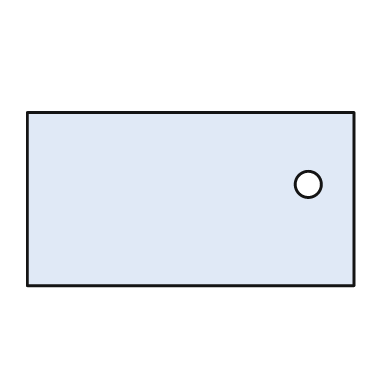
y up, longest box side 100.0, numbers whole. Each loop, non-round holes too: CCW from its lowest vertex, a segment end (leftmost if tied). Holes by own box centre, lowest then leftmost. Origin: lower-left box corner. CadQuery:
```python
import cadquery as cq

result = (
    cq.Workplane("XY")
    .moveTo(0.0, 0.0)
    .lineTo(100.0, 0.0)
    .lineTo(100.0, 53.0)
    .lineTo(0.0, 53.0)
    .close()
    .moveTo(86.0, 31.0)
    .circle(4.0)
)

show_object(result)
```